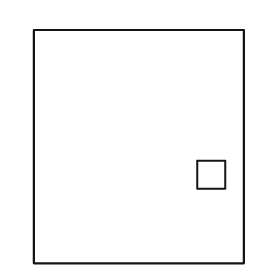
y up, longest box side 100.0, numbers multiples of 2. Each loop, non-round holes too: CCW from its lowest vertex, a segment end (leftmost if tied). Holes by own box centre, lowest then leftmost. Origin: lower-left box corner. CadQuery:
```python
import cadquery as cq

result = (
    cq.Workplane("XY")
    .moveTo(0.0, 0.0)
    .lineTo(90.0, 0.0)
    .lineTo(90.0, 100.0)
    .lineTo(0.0, 100.0)
    .close()
    .moveTo(70.0, 32.0)
    .lineTo(82.0, 32.0)
    .lineTo(82.0, 44.0)
    .lineTo(70.0, 44.0)
    .close()
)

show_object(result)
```